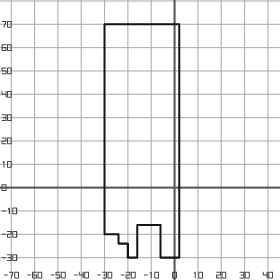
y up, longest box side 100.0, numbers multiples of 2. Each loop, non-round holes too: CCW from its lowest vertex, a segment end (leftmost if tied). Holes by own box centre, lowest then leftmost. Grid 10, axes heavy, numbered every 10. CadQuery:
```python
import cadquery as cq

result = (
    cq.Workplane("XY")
    .moveTo(-20.0, -30.0)
    .lineTo(-16.0, -30.0)
    .lineTo(-16.0, -16.0)
    .lineTo(-6.0, -16.0)
    .lineTo(-6.0, -30.0)
    .lineTo(2.0, -30.0)
    .lineTo(2.0, 70.0)
    .lineTo(-30.0, 70.0)
    .lineTo(-30.0, -20.0)
    .lineTo(-24.0, -20.0)
    .lineTo(-24.0, -24.0)
    .lineTo(-20.0, -24.0)
    .close()
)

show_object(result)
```